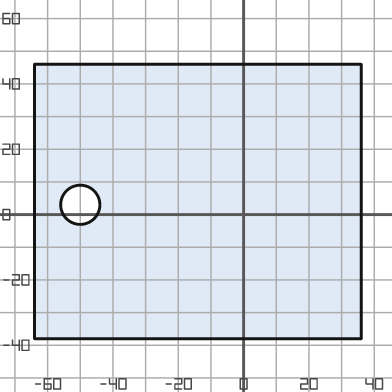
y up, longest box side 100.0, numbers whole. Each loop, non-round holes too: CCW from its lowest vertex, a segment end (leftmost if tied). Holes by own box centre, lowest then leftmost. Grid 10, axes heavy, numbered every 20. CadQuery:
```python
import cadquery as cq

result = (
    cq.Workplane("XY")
    .moveTo(-64.0, -38.0)
    .lineTo(36.0, -38.0)
    .lineTo(36.0, 46.0)
    .lineTo(-64.0, 46.0)
    .close()
    .moveTo(-50.0, 3.0)
    .circle(6.0)
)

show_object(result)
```